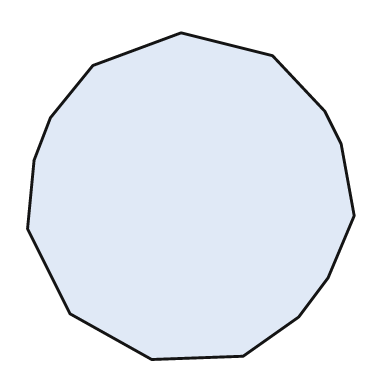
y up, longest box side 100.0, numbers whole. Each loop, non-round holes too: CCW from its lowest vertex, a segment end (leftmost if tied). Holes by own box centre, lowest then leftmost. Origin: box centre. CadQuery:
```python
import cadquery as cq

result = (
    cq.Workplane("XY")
    .moveTo(-12.0, -50.0)
    .lineTo(16.0, -49.0)
    .lineTo(33.0, -37.0)
    .lineTo(42.0, -25.0)
    .lineTo(50.0, -6.0)
    .lineTo(46.0, 16.0)
    .lineTo(41.0, 26.0)
    .lineTo(25.0, 43.0)
    .lineTo(-3.0, 50.0)
    .lineTo(-30.0, 40.0)
    .lineTo(-43.0, 24.0)
    .lineTo(-48.0, 11.0)
    .lineTo(-50.0, -10.0)
    .lineTo(-37.0, -36.0)
    .close()
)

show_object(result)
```